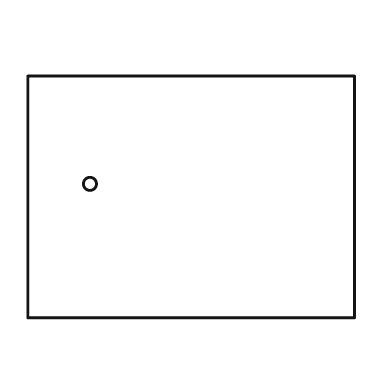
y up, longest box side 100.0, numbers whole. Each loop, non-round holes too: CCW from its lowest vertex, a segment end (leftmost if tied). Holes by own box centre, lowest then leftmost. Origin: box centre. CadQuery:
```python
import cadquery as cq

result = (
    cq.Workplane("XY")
    .moveTo(-50.0, -37.0)
    .lineTo(50.0, -37.0)
    .lineTo(50.0, 37.0)
    .lineTo(-50.0, 37.0)
    .close()
    .moveTo(-31.0, 4.0)
    .circle(2.0)
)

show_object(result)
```